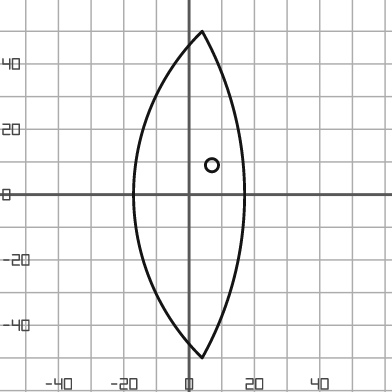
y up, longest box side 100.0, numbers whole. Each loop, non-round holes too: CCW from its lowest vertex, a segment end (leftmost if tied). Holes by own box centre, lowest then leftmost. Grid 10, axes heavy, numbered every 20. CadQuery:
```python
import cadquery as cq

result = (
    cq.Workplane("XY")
    .moveTo(4.0, -50.0)
    .threePointArc((17.0, 0.0), (4.0, 50.0))
    .threePointArc((-17.0, 0.0), (4.0, -50.0))
    .close()
    .moveTo(7.0, 9.0)
    .circle(2.0)
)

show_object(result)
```